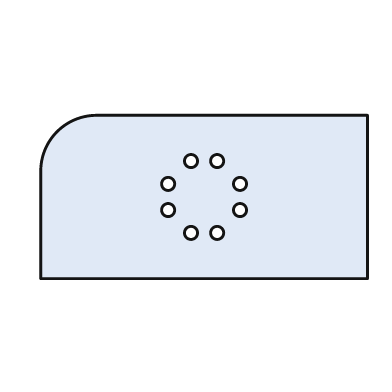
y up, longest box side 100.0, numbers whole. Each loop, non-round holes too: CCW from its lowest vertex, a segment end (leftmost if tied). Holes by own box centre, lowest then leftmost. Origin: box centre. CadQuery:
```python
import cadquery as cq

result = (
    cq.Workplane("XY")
    .moveTo(-50.0, -25.0)
    .lineTo(50.0, -25.0)
    .lineTo(50.0, 25.0)
    .lineTo(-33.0, 25.0)
    .threePointArc((-45.0, 20.0), (-50.0, 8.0))
    .close()
    .moveTo(-4.0, -11.0)
    .circle(2.0)
    .moveTo(4.0, -11.0)
    .circle(2.0)
    .moveTo(-11.0, -4.0)
    .circle(2.0)
    .moveTo(11.0, -4.0)
    .circle(2.0)
    .moveTo(-11.0, 4.0)
    .circle(2.0)
    .moveTo(11.0, 4.0)
    .circle(2.0)
    .moveTo(-4.0, 11.0)
    .circle(2.0)
    .moveTo(4.0, 11.0)
    .circle(2.0)
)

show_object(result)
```